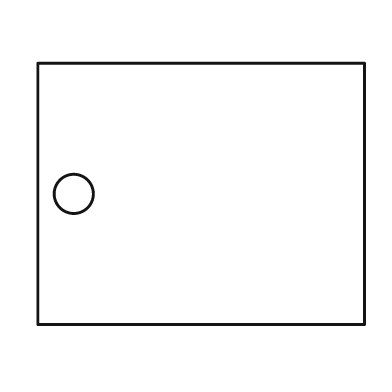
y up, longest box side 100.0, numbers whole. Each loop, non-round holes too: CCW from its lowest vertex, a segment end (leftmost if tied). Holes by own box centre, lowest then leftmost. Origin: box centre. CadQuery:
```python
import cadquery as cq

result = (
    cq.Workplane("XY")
    .moveTo(-50.0, -40.0)
    .lineTo(50.0, -40.0)
    .lineTo(50.0, 40.0)
    .lineTo(-50.0, 40.0)
    .close()
    .moveTo(-39.0, 0.0)
    .circle(6.0)
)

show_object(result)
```